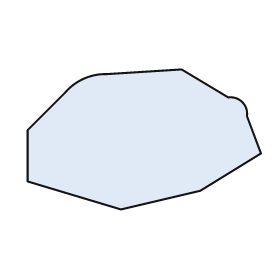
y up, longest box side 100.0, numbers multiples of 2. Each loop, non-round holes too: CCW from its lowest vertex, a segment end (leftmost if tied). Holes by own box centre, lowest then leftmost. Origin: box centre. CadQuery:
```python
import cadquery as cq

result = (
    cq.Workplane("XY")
    .moveTo(-10.0, -30.0)
    .lineTo(24.0, -22.0)
    .lineTo(50.0, -6.0)
    .lineTo(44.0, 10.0)
    .threePointArc((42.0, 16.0), (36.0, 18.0))
    .lineTo(16.0, 30.0)
    .lineTo(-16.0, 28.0)
    .threePointArc((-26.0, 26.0), (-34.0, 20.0))
    .lineTo(-50.0, 4.0)
    .lineTo(-50.0, -18.0)
    .close()
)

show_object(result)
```